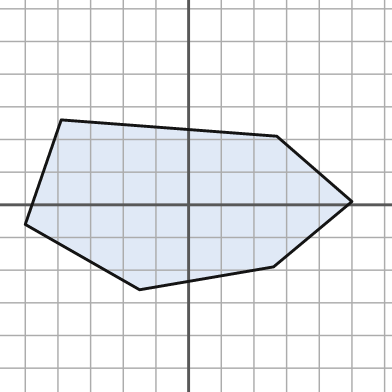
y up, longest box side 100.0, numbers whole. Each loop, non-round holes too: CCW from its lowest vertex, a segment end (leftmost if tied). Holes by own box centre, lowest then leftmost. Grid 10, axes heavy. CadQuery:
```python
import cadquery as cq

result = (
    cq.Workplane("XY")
    .moveTo(-15.0, -26.0)
    .lineTo(26.0, -19.0)
    .lineTo(50.0, 1.0)
    .lineTo(27.0, 21.0)
    .lineTo(-39.0, 26.0)
    .lineTo(-50.0, -6.0)
    .close()
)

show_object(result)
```